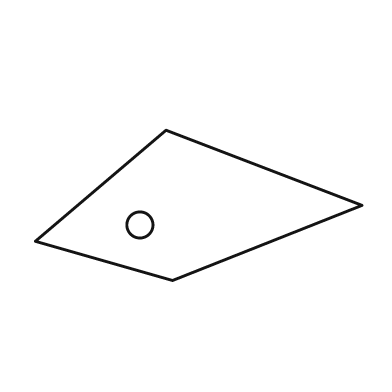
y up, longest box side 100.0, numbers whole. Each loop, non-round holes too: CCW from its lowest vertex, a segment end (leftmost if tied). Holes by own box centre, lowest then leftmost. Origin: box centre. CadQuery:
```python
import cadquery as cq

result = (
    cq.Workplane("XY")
    .moveTo(-8.0, -23.0)
    .lineTo(50.0, 0.0)
    .lineTo(-10.0, 23.0)
    .lineTo(-50.0, -11.0)
    .close()
    .moveTo(-18.0, -6.0)
    .circle(4.0)
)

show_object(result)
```